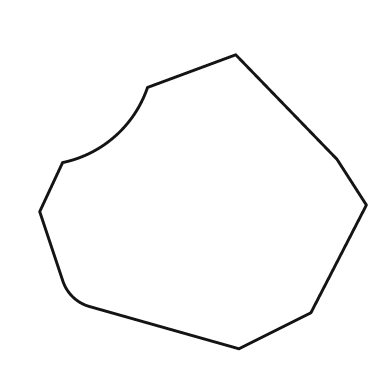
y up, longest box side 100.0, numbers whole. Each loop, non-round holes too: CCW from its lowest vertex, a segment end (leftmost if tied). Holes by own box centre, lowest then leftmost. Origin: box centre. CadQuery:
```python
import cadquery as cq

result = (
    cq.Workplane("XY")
    .moveTo(11.0, -45.0)
    .lineTo(33.0, -34.0)
    .lineTo(50.0, -1.0)
    .lineTo(41.0, 13.0)
    .lineTo(10.0, 45.0)
    .lineTo(-17.0, 35.0)
    .threePointArc((-27.0, 20.0), (-43.0, 12.0))
    .lineTo(-50.0, -3.0)
    .lineTo(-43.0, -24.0)
    .threePointArc((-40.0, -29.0), (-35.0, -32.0))
    .close()
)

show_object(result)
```